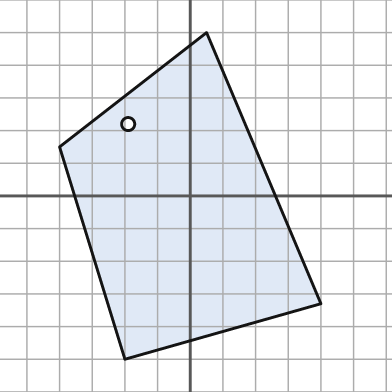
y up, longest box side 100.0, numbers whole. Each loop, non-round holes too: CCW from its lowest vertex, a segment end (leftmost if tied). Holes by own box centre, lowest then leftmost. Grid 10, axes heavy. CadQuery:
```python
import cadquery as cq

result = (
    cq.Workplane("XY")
    .moveTo(-20.0, -50.0)
    .lineTo(40.0, -33.0)
    .lineTo(5.0, 50.0)
    .lineTo(-40.0, 15.0)
    .close()
    .moveTo(-19.0, 22.0)
    .circle(2.0)
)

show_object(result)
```